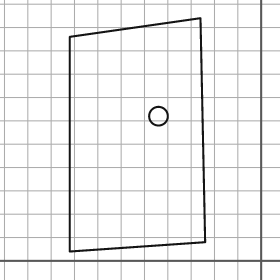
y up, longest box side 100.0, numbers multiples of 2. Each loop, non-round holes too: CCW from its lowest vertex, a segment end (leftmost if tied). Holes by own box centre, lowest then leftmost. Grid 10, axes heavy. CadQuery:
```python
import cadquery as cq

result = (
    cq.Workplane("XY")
    .moveTo(-82.0, 4.0)
    .lineTo(-24.0, 8.0)
    .lineTo(-26.0, 104.0)
    .lineTo(-82.0, 96.0)
    .close()
    .moveTo(-44.0, 62.0)
    .circle(4.0)
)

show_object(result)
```